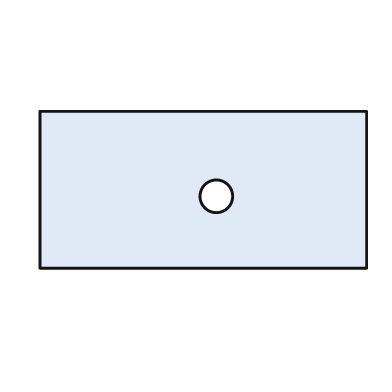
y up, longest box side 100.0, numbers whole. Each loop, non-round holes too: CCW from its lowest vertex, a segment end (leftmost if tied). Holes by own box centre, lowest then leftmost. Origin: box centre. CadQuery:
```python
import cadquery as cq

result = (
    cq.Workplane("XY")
    .moveTo(-50.0, -24.0)
    .lineTo(50.0, -24.0)
    .lineTo(50.0, 24.0)
    .lineTo(-50.0, 24.0)
    .close()
    .moveTo(4.0, -2.0)
    .circle(5.0)
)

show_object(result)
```